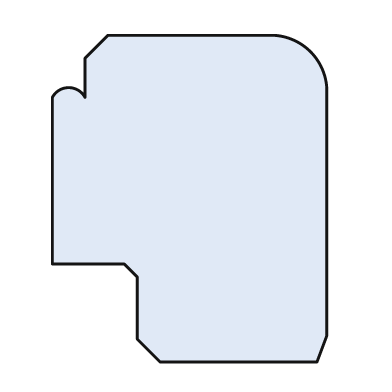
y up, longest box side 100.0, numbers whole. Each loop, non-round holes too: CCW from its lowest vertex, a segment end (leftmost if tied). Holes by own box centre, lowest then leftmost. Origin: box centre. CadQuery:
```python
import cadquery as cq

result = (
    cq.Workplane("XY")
    .moveTo(-9.0, -50.0)
    .lineTo(39.0, -50.0)
    .lineTo(42.0, -42.0)
    .lineTo(42.0, 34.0)
    .threePointArc((37.0, 45.0), (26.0, 50.0))
    .lineTo(-25.0, 50.0)
    .lineTo(-32.0, 43.0)
    .lineTo(-32.0, 31.0)
    .threePointArc((-37.0, 34.0), (-42.0, 31.0))
    .lineTo(-42.0, -20.0)
    .lineTo(-20.0, -20.0)
    .lineTo(-16.0, -24.0)
    .lineTo(-16.0, -43.0)
    .close()
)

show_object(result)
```